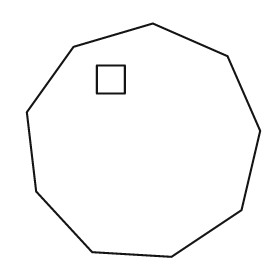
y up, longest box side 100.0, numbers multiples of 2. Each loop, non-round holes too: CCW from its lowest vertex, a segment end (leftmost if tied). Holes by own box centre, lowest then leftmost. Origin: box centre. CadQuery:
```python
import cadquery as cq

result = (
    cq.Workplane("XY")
    .moveTo(12.0, -50.0)
    .lineTo(42.0, -30.0)
    .lineTo(50.0, 4.0)
    .lineTo(36.0, 36.0)
    .lineTo(4.0, 50.0)
    .lineTo(-30.0, 40.0)
    .lineTo(-50.0, 12.0)
    .lineTo(-46.0, -22.0)
    .lineTo(-22.0, -48.0)
    .close()
    .moveTo(-20.0, 20.0)
    .lineTo(-8.0, 20.0)
    .lineTo(-8.0, 32.0)
    .lineTo(-20.0, 32.0)
    .close()
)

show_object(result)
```